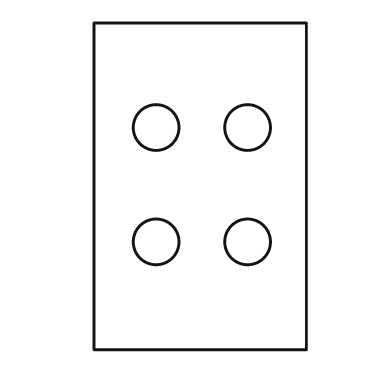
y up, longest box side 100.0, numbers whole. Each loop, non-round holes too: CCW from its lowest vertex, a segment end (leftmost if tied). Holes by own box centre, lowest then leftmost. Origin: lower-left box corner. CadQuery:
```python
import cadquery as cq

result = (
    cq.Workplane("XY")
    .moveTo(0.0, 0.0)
    .lineTo(65.0, 0.0)
    .lineTo(65.0, 100.0)
    .lineTo(0.0, 100.0)
    .close()
    .moveTo(19.0, 33.0)
    .circle(7.0)
    .moveTo(47.0, 33.0)
    .circle(7.0)
    .moveTo(19.0, 68.0)
    .circle(7.0)
    .moveTo(47.0, 68.0)
    .circle(7.0)
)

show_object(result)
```